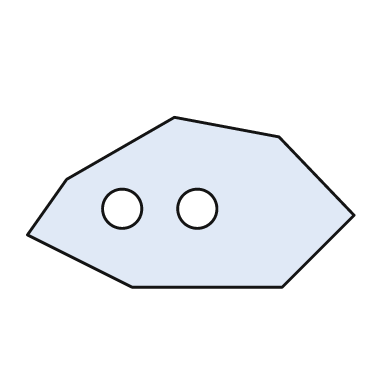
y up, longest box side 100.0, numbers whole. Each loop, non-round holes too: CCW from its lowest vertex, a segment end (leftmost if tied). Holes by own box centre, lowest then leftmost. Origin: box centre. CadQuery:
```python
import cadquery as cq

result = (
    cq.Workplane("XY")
    .moveTo(-18.0, -26.0)
    .lineTo(28.0, -26.0)
    .lineTo(50.0, -4.0)
    .lineTo(27.0, 20.0)
    .lineTo(-5.0, 26.0)
    .lineTo(-38.0, 7.0)
    .lineTo(-50.0, -10.0)
    .close()
    .moveTo(-21.0, -2.0)
    .circle(6.0)
    .moveTo(2.0, -2.0)
    .circle(6.0)
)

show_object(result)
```